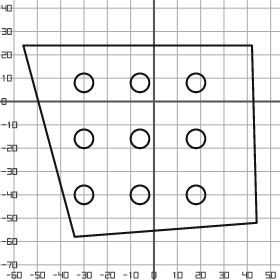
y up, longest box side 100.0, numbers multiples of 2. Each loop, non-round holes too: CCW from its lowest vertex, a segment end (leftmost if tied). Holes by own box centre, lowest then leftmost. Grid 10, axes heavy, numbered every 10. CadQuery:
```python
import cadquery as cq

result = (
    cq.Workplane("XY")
    .moveTo(-34.0, -58.0)
    .lineTo(44.0, -52.0)
    .lineTo(42.0, 24.0)
    .lineTo(-56.0, 24.0)
    .close()
    .moveTo(-30.0, -40.0)
    .circle(4.0)
    .moveTo(-6.0, -40.0)
    .circle(4.0)
    .moveTo(18.0, -40.0)
    .circle(4.0)
    .moveTo(-30.0, -16.0)
    .circle(4.0)
    .moveTo(-6.0, -16.0)
    .circle(4.0)
    .moveTo(18.0, -16.0)
    .circle(4.0)
    .moveTo(-30.0, 8.0)
    .circle(4.0)
    .moveTo(-6.0, 8.0)
    .circle(4.0)
    .moveTo(18.0, 8.0)
    .circle(4.0)
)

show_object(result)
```